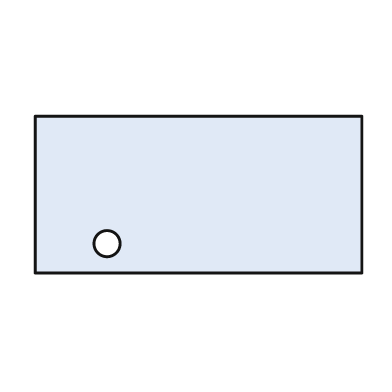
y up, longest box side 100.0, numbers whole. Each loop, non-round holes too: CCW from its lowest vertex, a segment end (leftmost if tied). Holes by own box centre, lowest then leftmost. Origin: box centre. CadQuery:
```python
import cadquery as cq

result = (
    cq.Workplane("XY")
    .moveTo(-50.0, -24.0)
    .lineTo(50.0, -24.0)
    .lineTo(50.0, 24.0)
    .lineTo(-50.0, 24.0)
    .close()
    .moveTo(-28.0, -15.0)
    .circle(4.0)
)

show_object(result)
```